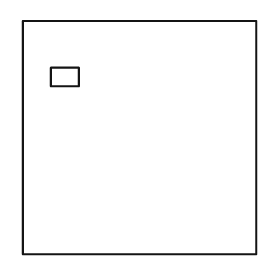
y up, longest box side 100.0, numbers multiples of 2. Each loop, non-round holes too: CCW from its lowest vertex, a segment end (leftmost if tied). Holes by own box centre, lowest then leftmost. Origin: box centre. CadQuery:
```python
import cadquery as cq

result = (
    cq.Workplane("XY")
    .moveTo(-50.0, -50.0)
    .lineTo(50.0, -50.0)
    .lineTo(50.0, 50.0)
    .lineTo(-50.0, 50.0)
    .close()
    .moveTo(-38.0, 22.0)
    .lineTo(-26.0, 22.0)
    .lineTo(-26.0, 30.0)
    .lineTo(-38.0, 30.0)
    .close()
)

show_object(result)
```